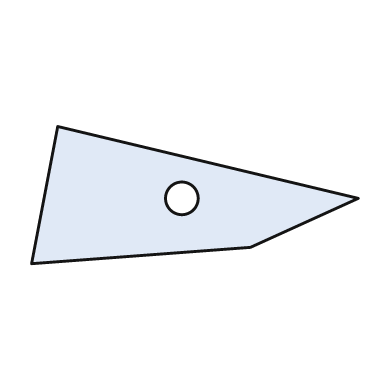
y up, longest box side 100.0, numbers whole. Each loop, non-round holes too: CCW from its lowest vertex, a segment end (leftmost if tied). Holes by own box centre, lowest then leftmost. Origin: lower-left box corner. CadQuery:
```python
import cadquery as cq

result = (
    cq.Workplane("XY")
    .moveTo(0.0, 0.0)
    .lineTo(67.0, 5.0)
    .lineTo(100.0, 20.0)
    .lineTo(8.0, 42.0)
    .close()
    .moveTo(46.0, 20.0)
    .circle(5.0)
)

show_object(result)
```